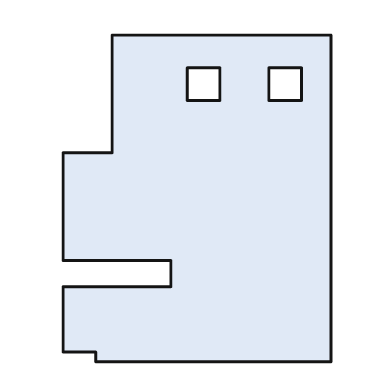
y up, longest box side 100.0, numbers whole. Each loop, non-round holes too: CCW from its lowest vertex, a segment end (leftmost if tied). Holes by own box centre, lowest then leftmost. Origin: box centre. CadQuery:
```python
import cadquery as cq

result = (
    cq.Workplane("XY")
    .moveTo(-31.0, -50.0)
    .lineTo(41.0, -50.0)
    .lineTo(41.0, 50.0)
    .lineTo(-26.0, 50.0)
    .lineTo(-26.0, 14.0)
    .lineTo(-41.0, 14.0)
    .lineTo(-41.0, -19.0)
    .lineTo(-8.0, -19.0)
    .lineTo(-8.0, -27.0)
    .lineTo(-41.0, -27.0)
    .lineTo(-41.0, -47.0)
    .lineTo(-31.0, -47.0)
    .close()
    .moveTo(-3.0, 30.0)
    .lineTo(7.0, 30.0)
    .lineTo(7.0, 40.0)
    .lineTo(-3.0, 40.0)
    .close()
    .moveTo(22.0, 30.0)
    .lineTo(32.0, 30.0)
    .lineTo(32.0, 40.0)
    .lineTo(22.0, 40.0)
    .close()
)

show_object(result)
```